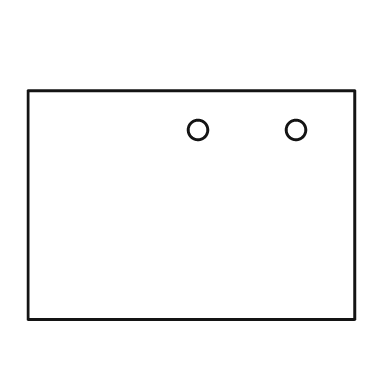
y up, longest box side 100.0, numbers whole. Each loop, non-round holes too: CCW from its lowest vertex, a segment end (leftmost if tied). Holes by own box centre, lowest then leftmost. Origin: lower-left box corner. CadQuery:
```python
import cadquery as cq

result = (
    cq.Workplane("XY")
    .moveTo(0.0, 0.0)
    .lineTo(100.0, 0.0)
    .lineTo(100.0, 70.0)
    .lineTo(0.0, 70.0)
    .close()
    .moveTo(52.0, 58.0)
    .circle(3.0)
    .moveTo(82.0, 58.0)
    .circle(3.0)
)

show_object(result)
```